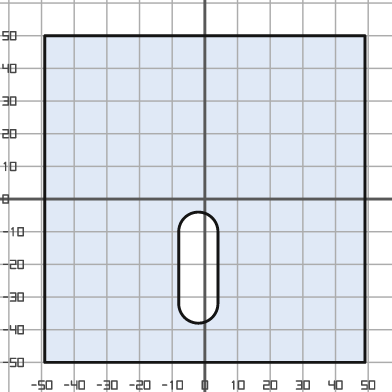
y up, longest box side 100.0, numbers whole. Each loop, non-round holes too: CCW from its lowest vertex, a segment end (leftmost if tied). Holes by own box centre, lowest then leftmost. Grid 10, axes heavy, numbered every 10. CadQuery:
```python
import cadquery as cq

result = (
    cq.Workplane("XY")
    .moveTo(-49.0, -50.0)
    .lineTo(49.0, -50.0)
    .lineTo(49.0, 50.0)
    .lineTo(-49.0, 50.0)
    .close()
    .moveTo(-8.0, -32.0)
    .threePointArc((-2.0, -38.0), (4.0, -32.0))
    .lineTo(4.0, -10.0)
    .threePointArc((-2.0, -4.0), (-8.0, -10.0))
    .close()
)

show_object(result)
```